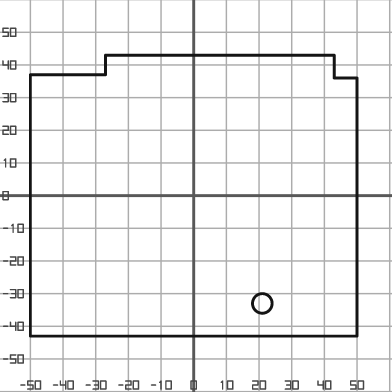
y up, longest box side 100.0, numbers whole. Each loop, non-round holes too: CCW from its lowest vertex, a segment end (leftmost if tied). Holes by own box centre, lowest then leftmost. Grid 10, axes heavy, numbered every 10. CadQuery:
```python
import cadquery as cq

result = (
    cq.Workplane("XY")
    .moveTo(-50.0, -43.0)
    .lineTo(50.0, -43.0)
    .lineTo(50.0, 36.0)
    .lineTo(43.0, 36.0)
    .lineTo(43.0, 43.0)
    .lineTo(-27.0, 43.0)
    .lineTo(-27.0, 37.0)
    .lineTo(-50.0, 37.0)
    .close()
    .moveTo(21.0, -33.0)
    .circle(3.0)
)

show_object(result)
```